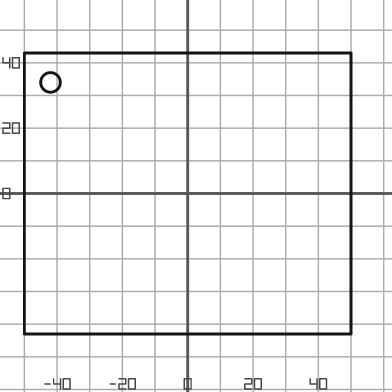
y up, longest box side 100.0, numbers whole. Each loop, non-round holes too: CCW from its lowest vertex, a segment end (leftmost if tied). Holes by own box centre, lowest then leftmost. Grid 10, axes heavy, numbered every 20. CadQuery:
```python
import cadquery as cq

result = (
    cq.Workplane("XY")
    .moveTo(-50.0, -43.0)
    .lineTo(50.0, -43.0)
    .lineTo(50.0, 43.0)
    .lineTo(-50.0, 43.0)
    .close()
    .moveTo(-42.0, 34.0)
    .circle(3.0)
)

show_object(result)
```